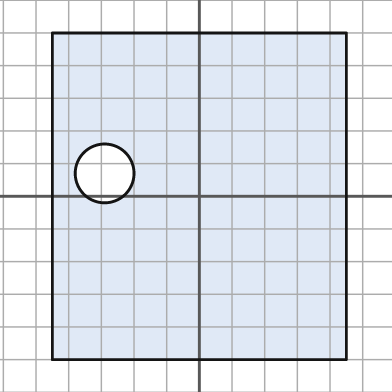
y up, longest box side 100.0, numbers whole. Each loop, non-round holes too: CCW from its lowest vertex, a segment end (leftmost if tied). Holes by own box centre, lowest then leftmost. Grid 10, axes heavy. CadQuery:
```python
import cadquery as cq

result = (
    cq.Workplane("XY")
    .moveTo(-45.0, -50.0)
    .lineTo(45.0, -50.0)
    .lineTo(45.0, 50.0)
    .lineTo(-45.0, 50.0)
    .close()
    .moveTo(-29.0, 7.0)
    .circle(9.0)
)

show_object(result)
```